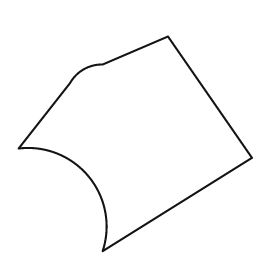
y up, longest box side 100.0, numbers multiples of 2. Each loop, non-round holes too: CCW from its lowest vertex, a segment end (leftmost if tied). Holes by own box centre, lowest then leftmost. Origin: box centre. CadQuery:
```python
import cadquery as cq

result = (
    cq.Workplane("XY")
    .moveTo(-14.0, -46.0)
    .lineTo(50.0, -6.0)
    .lineTo(14.0, 46.0)
    .lineTo(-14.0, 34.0)
    .threePointArc((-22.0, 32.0), (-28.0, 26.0))
    .lineTo(-50.0, -2.0)
    .threePointArc((-20.0, -14.0), (-14.0, -46.0))
    .close()
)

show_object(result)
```